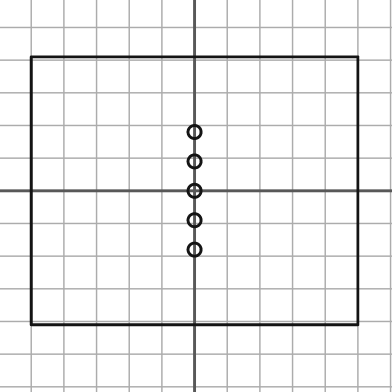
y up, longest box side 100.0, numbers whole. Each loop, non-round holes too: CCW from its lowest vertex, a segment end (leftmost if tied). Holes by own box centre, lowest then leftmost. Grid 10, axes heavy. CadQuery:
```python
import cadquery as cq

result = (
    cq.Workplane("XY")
    .moveTo(-50.0, -41.0)
    .lineTo(50.0, -41.0)
    .lineTo(50.0, 41.0)
    .lineTo(-50.0, 41.0)
    .close()
    .moveTo(0.0, -18.0)
    .circle(2.0)
    .moveTo(0.0, -9.0)
    .circle(2.0)
    .moveTo(0.0, 0.0)
    .circle(2.0)
    .moveTo(0.0, 9.0)
    .circle(2.0)
    .moveTo(0.0, 18.0)
    .circle(2.0)
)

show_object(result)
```